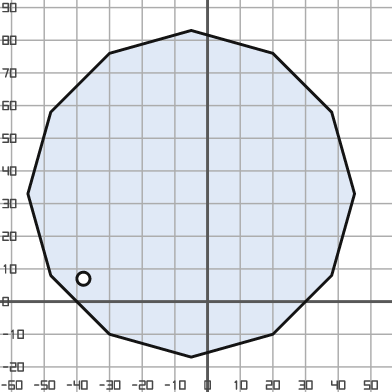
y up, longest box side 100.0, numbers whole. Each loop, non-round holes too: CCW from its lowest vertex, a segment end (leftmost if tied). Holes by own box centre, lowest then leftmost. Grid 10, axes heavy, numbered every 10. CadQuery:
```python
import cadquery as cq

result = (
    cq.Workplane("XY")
    .moveTo(-5.0, -17.0)
    .lineTo(20.0, -10.0)
    .lineTo(38.0, 8.0)
    .lineTo(45.0, 33.0)
    .lineTo(38.0, 58.0)
    .lineTo(20.0, 76.0)
    .lineTo(-5.0, 83.0)
    .lineTo(-30.0, 76.0)
    .lineTo(-48.0, 58.0)
    .lineTo(-55.0, 33.0)
    .lineTo(-48.0, 8.0)
    .lineTo(-30.0, -10.0)
    .close()
    .moveTo(-38.0, 7.0)
    .circle(2.0)
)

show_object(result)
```